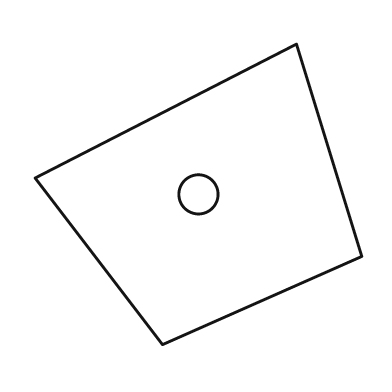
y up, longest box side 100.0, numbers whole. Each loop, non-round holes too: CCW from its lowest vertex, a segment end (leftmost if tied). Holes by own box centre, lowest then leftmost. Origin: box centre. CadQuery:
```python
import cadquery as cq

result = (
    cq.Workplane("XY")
    .moveTo(-11.0, -46.0)
    .lineTo(50.0, -19.0)
    .lineTo(30.0, 46.0)
    .lineTo(-50.0, 5.0)
    .close()
    .moveTo(0.0, 0.0)
    .circle(6.0)
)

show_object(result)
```